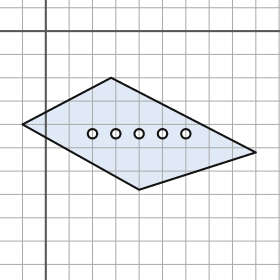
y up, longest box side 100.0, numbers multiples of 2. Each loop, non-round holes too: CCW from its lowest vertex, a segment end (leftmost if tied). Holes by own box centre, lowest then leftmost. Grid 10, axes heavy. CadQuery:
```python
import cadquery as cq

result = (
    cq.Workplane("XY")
    .moveTo(40.0, -68.0)
    .lineTo(90.0, -52.0)
    .lineTo(28.0, -20.0)
    .lineTo(-10.0, -40.0)
    .close()
    .moveTo(20.0, -44.0)
    .circle(2.0)
    .moveTo(30.0, -44.0)
    .circle(2.0)
    .moveTo(40.0, -44.0)
    .circle(2.0)
    .moveTo(50.0, -44.0)
    .circle(2.0)
    .moveTo(60.0, -44.0)
    .circle(2.0)
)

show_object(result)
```